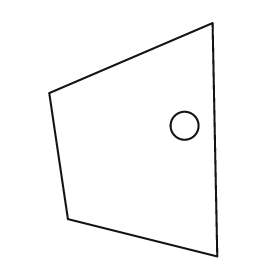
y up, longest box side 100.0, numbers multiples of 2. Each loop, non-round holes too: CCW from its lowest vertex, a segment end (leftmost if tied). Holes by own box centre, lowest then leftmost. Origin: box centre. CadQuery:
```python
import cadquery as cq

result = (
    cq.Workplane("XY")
    .moveTo(36.0, -50.0)
    .lineTo(34.0, 50.0)
    .lineTo(-36.0, 20.0)
    .lineTo(-28.0, -34.0)
    .close()
    .moveTo(22.0, 6.0)
    .circle(6.0)
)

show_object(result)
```